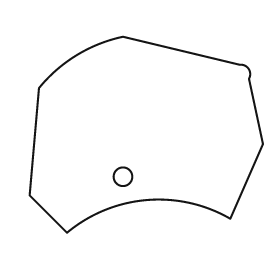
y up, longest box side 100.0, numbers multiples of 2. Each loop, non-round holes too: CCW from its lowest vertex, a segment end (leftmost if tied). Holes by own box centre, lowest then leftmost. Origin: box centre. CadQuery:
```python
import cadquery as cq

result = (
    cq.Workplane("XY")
    .moveTo(-34.0, -42.0)
    .threePointArc((0.0, -28.0), (36.0, -36.0))
    .lineTo(50.0, -4.0)
    .lineTo(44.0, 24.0)
    .threePointArc((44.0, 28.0), (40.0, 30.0))
    .lineTo(-10.0, 42.0)
    .threePointArc((-30.0, 34.0), (-46.0, 20.0))
    .lineTo(-50.0, -26.0)
    .close()
    .moveTo(-10.0, -18.0)
    .circle(4.0)
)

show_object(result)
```